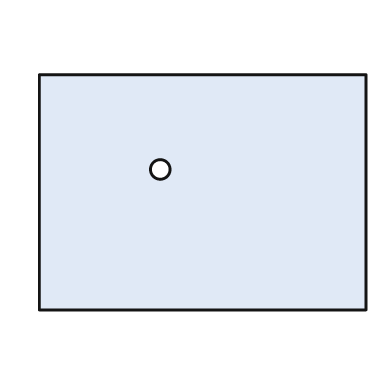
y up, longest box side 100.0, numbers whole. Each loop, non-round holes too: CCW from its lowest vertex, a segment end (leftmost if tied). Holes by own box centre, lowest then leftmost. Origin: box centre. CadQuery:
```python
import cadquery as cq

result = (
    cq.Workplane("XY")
    .moveTo(-50.0, -36.0)
    .lineTo(50.0, -36.0)
    .lineTo(50.0, 36.0)
    .lineTo(-50.0, 36.0)
    .close()
    .moveTo(-13.0, 7.0)
    .circle(3.0)
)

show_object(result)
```